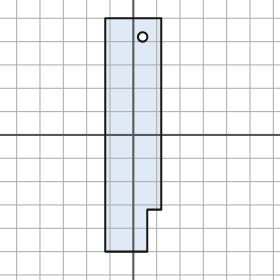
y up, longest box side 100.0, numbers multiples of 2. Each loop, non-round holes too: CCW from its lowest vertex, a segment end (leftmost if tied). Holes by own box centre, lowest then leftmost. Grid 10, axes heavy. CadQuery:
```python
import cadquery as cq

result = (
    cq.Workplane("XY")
    .moveTo(-12.0, -50.0)
    .lineTo(6.0, -50.0)
    .lineTo(6.0, -32.0)
    .lineTo(12.0, -32.0)
    .lineTo(12.0, 50.0)
    .lineTo(-12.0, 50.0)
    .close()
    .moveTo(4.0, 42.0)
    .circle(2.0)
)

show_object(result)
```